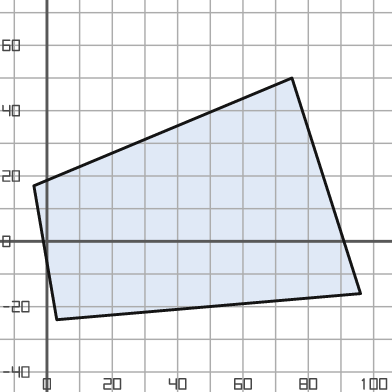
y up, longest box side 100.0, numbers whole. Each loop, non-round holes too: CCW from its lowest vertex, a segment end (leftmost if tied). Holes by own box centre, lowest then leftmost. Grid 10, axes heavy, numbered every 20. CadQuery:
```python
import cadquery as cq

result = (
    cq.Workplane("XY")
    .moveTo(3.0, -24.0)
    .lineTo(96.0, -16.0)
    .lineTo(75.0, 50.0)
    .lineTo(-4.0, 17.0)
    .close()
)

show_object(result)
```